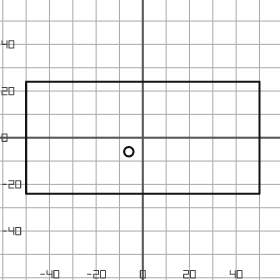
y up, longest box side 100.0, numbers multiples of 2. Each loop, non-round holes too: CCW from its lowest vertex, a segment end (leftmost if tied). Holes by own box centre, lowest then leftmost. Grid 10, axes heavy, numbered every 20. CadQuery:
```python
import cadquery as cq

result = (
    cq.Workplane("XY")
    .moveTo(-50.0, -24.0)
    .lineTo(50.0, -24.0)
    .lineTo(50.0, 24.0)
    .lineTo(-50.0, 24.0)
    .close()
    .moveTo(-6.0, -6.0)
    .circle(2.0)
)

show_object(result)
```